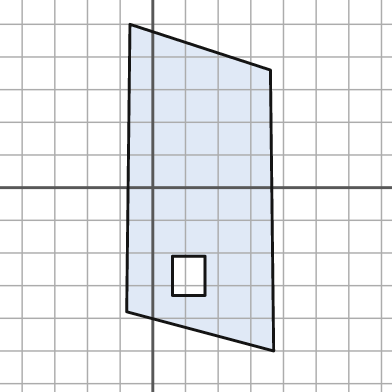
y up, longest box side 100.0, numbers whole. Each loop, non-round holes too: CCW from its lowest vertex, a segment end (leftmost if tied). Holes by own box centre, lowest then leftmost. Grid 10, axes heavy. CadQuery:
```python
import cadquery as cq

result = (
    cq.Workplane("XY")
    .moveTo(37.0, -50.0)
    .lineTo(36.0, 36.0)
    .lineTo(-7.0, 50.0)
    .lineTo(-8.0, -38.0)
    .close()
    .moveTo(6.0, -33.0)
    .lineTo(16.0, -33.0)
    .lineTo(16.0, -21.0)
    .lineTo(6.0, -21.0)
    .close()
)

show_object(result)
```